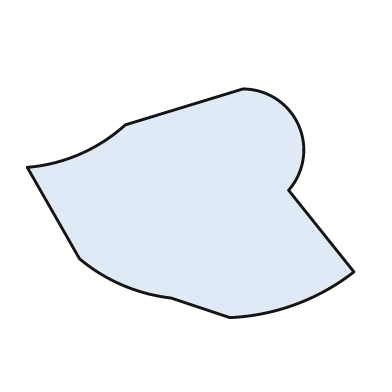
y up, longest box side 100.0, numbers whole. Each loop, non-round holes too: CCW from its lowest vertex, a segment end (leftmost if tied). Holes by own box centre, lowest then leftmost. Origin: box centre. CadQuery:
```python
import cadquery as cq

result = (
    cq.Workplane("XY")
    .moveTo(12.0, -35.0)
    .threePointArc((32.0, -31.0), (50.0, -21.0))
    .lineTo(30.0, 4.0)
    .threePointArc((33.0, 24.0), (16.0, 35.0))
    .lineTo(-20.0, 24.0)
    .threePointArc((-34.0, 15.0), (-50.0, 11.0))
    .lineTo(-34.0, -17.0)
    .threePointArc((-21.0, -25.0), (-6.0, -29.0))
    .close()
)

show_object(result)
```